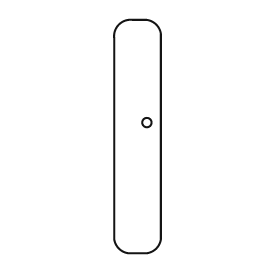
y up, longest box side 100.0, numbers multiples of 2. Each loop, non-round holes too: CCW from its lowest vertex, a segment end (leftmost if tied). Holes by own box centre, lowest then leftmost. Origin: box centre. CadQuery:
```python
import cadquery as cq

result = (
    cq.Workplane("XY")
    .moveTo(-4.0, -50.0)
    .lineTo(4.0, -50.0)
    .threePointArc((8.0, -48.0), (10.0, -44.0))
    .lineTo(10.0, 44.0)
    .threePointArc((8.0, 48.0), (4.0, 50.0))
    .lineTo(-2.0, 50.0)
    .threePointArc((-8.0, 48.0), (-10.0, 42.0))
    .lineTo(-10.0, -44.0)
    .threePointArc((-8.0, -48.0), (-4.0, -50.0))
    .close()
    .moveTo(4.0, 6.0)
    .circle(2.0)
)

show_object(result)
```